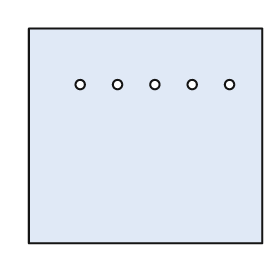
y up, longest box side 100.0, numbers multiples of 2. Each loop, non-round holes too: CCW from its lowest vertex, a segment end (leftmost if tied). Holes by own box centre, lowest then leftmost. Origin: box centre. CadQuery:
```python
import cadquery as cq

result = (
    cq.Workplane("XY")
    .moveTo(-50.0, -46.0)
    .lineTo(50.0, -46.0)
    .lineTo(50.0, 46.0)
    .lineTo(-50.0, 46.0)
    .close()
    .moveTo(-28.0, 22.0)
    .circle(2.0)
    .moveTo(-12.0, 22.0)
    .circle(2.0)
    .moveTo(4.0, 22.0)
    .circle(2.0)
    .moveTo(20.0, 22.0)
    .circle(2.0)
    .moveTo(36.0, 22.0)
    .circle(2.0)
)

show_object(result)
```